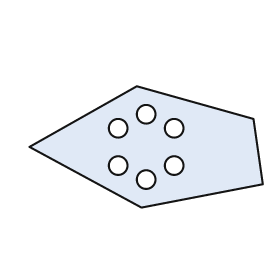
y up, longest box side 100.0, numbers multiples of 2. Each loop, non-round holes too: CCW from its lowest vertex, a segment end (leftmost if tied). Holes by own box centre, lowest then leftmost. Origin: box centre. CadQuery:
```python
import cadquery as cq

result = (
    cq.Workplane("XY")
    .moveTo(-2.0, -26.0)
    .lineTo(50.0, -16.0)
    .lineTo(46.0, 12.0)
    .lineTo(-4.0, 26.0)
    .lineTo(-50.0, 0.0)
    .close()
    .moveTo(0.0, -14.0)
    .circle(4.0)
    .moveTo(-12.0, -8.0)
    .circle(4.0)
    .moveTo(12.0, -8.0)
    .circle(4.0)
    .moveTo(-12.0, 8.0)
    .circle(4.0)
    .moveTo(12.0, 8.0)
    .circle(4.0)
    .moveTo(0.0, 14.0)
    .circle(4.0)
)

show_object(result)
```